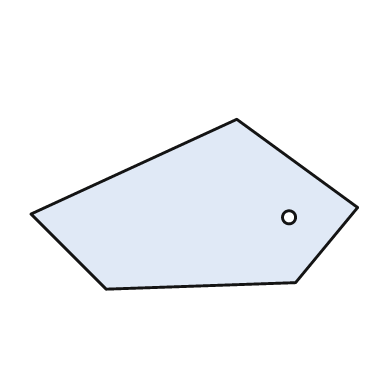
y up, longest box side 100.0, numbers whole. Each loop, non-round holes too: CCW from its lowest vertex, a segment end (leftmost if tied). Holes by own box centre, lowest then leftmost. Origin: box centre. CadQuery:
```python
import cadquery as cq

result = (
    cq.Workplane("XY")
    .moveTo(-27.0, -26.0)
    .lineTo(31.0, -24.0)
    .lineTo(50.0, -1.0)
    .lineTo(13.0, 26.0)
    .lineTo(-50.0, -3.0)
    .close()
    .moveTo(29.0, -4.0)
    .circle(2.0)
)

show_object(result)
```